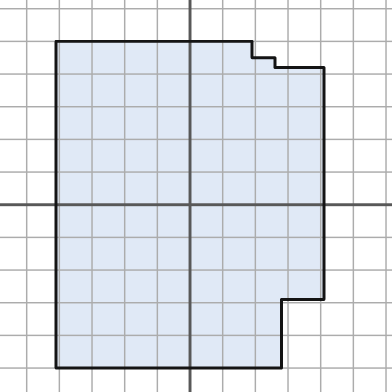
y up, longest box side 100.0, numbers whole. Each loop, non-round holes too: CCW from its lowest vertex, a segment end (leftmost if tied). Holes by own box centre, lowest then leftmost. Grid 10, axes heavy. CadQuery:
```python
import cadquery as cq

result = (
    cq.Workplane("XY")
    .moveTo(-41.0, -50.0)
    .lineTo(28.0, -50.0)
    .lineTo(28.0, -29.0)
    .lineTo(41.0, -29.0)
    .lineTo(41.0, 42.0)
    .lineTo(26.0, 42.0)
    .lineTo(26.0, 45.0)
    .lineTo(19.0, 45.0)
    .lineTo(19.0, 50.0)
    .lineTo(-41.0, 50.0)
    .close()
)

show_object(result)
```